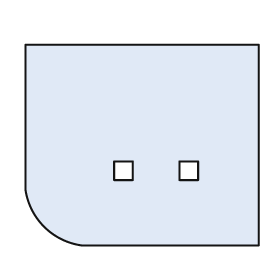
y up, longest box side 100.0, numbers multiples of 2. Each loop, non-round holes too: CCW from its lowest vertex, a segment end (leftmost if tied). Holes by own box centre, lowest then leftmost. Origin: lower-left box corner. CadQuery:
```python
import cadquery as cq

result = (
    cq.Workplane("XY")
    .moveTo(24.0, 0.0)
    .lineTo(100.0, 0.0)
    .lineTo(100.0, 86.0)
    .lineTo(0.0, 86.0)
    .lineTo(0.0, 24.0)
    .threePointArc((8.0, 8.0), (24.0, 0.0))
    .close()
    .moveTo(38.0, 28.0)
    .lineTo(46.0, 28.0)
    .lineTo(46.0, 36.0)
    .lineTo(38.0, 36.0)
    .close()
    .moveTo(66.0, 28.0)
    .lineTo(74.0, 28.0)
    .lineTo(74.0, 36.0)
    .lineTo(66.0, 36.0)
    .close()
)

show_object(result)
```